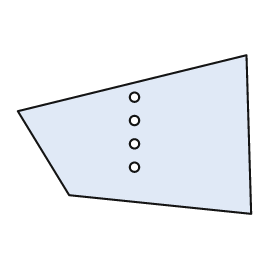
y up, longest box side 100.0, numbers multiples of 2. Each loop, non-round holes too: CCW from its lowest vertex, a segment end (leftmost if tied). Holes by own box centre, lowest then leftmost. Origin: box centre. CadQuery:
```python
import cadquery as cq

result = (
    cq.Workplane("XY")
    .moveTo(50.0, -34.0)
    .lineTo(48.0, 34.0)
    .lineTo(-50.0, 10.0)
    .lineTo(-28.0, -26.0)
    .close()
    .moveTo(0.0, -14.0)
    .circle(2.0)
    .moveTo(0.0, -4.0)
    .circle(2.0)
    .moveTo(0.0, 6.0)
    .circle(2.0)
    .moveTo(0.0, 16.0)
    .circle(2.0)
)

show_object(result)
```